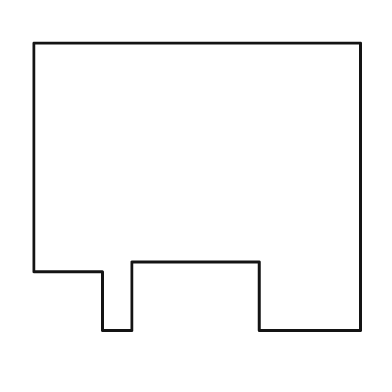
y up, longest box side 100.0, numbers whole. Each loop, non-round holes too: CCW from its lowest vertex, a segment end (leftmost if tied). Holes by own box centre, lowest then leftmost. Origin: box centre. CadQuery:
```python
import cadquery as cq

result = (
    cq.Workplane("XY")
    .moveTo(-29.0, -44.0)
    .lineTo(-20.0, -44.0)
    .lineTo(-20.0, -23.0)
    .lineTo(19.0, -23.0)
    .lineTo(19.0, -44.0)
    .lineTo(50.0, -44.0)
    .lineTo(50.0, 44.0)
    .lineTo(-50.0, 44.0)
    .lineTo(-50.0, -26.0)
    .lineTo(-29.0, -26.0)
    .close()
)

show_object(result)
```